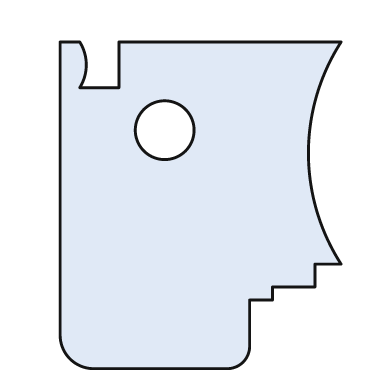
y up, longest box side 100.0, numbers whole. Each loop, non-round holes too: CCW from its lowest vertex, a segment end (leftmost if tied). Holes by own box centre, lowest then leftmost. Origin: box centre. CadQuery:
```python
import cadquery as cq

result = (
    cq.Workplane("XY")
    .moveTo(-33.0, -50.0)
    .lineTo(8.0, -50.0)
    .threePointArc((13.0, -48.0), (15.0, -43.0))
    .lineTo(15.0, -29.0)
    .lineTo(22.0, -29.0)
    .lineTo(22.0, -25.0)
    .lineTo(35.0, -25.0)
    .lineTo(35.0, -18.0)
    .lineTo(43.0, -18.0)
    .threePointArc((33.0, 16.0), (43.0, 50.0))
    .lineTo(-25.0, 50.0)
    .lineTo(-25.0, 36.0)
    .lineTo(-37.0, 36.0)
    .threePointArc((-35.0, 43.0), (-37.0, 50.0))
    .lineTo(-43.0, 50.0)
    .lineTo(-43.0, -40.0)
    .threePointArc((-40.0, -47.0), (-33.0, -50.0))
    .close()
    .moveTo(-11.0, 23.0)
    .circle(9.0)
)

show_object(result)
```